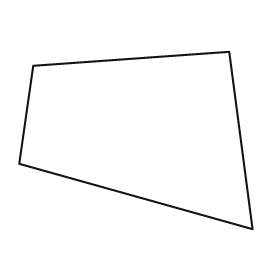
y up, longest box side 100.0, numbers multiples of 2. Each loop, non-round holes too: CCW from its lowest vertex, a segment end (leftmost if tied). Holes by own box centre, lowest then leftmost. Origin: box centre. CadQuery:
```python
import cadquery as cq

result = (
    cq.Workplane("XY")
    .moveTo(50.0, -38.0)
    .lineTo(40.0, 38.0)
    .lineTo(-44.0, 32.0)
    .lineTo(-50.0, -10.0)
    .close()
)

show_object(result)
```